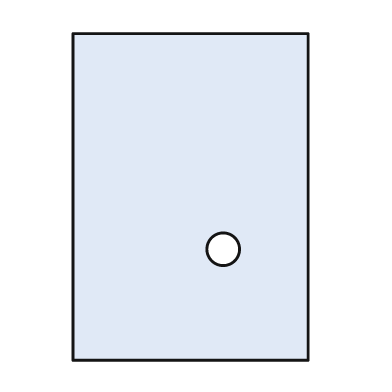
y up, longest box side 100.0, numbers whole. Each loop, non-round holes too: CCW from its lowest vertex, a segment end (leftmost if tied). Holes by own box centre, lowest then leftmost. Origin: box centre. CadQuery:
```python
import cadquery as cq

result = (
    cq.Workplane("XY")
    .moveTo(-36.0, -50.0)
    .lineTo(36.0, -50.0)
    .lineTo(36.0, 50.0)
    .lineTo(-36.0, 50.0)
    .close()
    .moveTo(10.0, -16.0)
    .circle(5.0)
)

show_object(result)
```